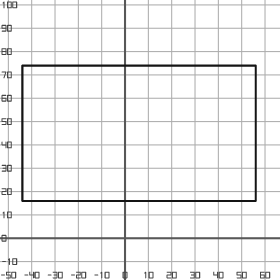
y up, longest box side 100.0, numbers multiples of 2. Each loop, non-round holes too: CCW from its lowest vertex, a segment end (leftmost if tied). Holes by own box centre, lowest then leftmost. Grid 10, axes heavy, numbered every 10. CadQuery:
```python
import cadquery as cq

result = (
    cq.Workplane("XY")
    .moveTo(-44.0, 16.0)
    .lineTo(56.0, 16.0)
    .lineTo(56.0, 74.0)
    .lineTo(-44.0, 74.0)
    .close()
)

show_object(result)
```